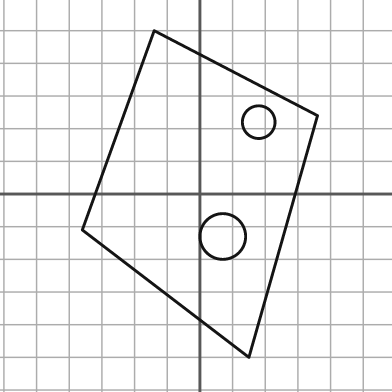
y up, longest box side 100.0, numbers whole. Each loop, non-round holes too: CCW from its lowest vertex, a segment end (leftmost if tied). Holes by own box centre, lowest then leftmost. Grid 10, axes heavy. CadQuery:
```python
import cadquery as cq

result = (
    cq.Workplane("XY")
    .moveTo(15.0, -50.0)
    .lineTo(36.0, 24.0)
    .lineTo(-14.0, 50.0)
    .lineTo(-36.0, -11.0)
    .close()
    .moveTo(7.0, -13.0)
    .circle(7.0)
    .moveTo(18.0, 22.0)
    .circle(5.0)
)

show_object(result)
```